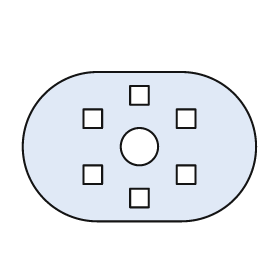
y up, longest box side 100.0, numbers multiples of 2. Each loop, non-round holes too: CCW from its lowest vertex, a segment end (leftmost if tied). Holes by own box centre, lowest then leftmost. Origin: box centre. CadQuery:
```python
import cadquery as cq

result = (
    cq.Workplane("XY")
    .moveTo(-18.0, -32.0)
    .lineTo(18.0, -32.0)
    .threePointArc((50.0, 0.0), (18.0, 32.0))
    .lineTo(-18.0, 32.0)
    .threePointArc((-50.0, 0.0), (-18.0, -32.0))
    .close()
    .moveTo(-4.0, -26.0)
    .lineTo(4.0, -26.0)
    .lineTo(4.0, -18.0)
    .lineTo(-4.0, -18.0)
    .close()
    .moveTo(-24.0, -16.0)
    .lineTo(-16.0, -16.0)
    .lineTo(-16.0, -8.0)
    .lineTo(-24.0, -8.0)
    .close()
    .moveTo(16.0, -16.0)
    .lineTo(24.0, -16.0)
    .lineTo(24.0, -8.0)
    .lineTo(16.0, -8.0)
    .close()
    .moveTo(0.0, 0.0)
    .circle(8.0)
    .moveTo(-24.0, 8.0)
    .lineTo(-16.0, 8.0)
    .lineTo(-16.0, 16.0)
    .lineTo(-24.0, 16.0)
    .close()
    .moveTo(16.0, 8.0)
    .lineTo(24.0, 8.0)
    .lineTo(24.0, 16.0)
    .lineTo(16.0, 16.0)
    .close()
    .moveTo(-4.0, 18.0)
    .lineTo(4.0, 18.0)
    .lineTo(4.0, 26.0)
    .lineTo(-4.0, 26.0)
    .close()
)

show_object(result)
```